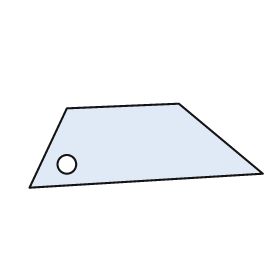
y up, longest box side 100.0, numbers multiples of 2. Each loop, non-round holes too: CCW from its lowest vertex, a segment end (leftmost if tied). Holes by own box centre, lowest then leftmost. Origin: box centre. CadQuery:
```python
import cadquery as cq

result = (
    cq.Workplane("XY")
    .moveTo(-50.0, -18.0)
    .lineTo(50.0, -12.0)
    .lineTo(14.0, 18.0)
    .lineTo(-34.0, 16.0)
    .close()
    .moveTo(-34.0, -8.0)
    .circle(4.0)
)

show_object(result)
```